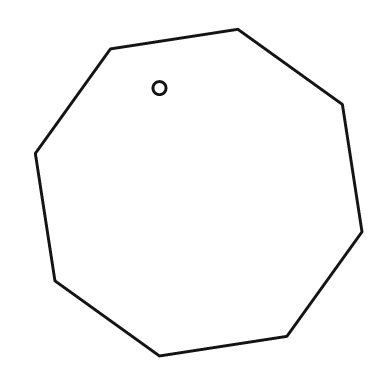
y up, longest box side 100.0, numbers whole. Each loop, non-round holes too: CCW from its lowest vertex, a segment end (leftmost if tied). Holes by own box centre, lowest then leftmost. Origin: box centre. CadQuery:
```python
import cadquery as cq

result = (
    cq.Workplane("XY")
    .moveTo(-12.0, -50.0)
    .lineTo(27.0, -44.0)
    .lineTo(50.0, -12.0)
    .lineTo(44.0, 27.0)
    .lineTo(12.0, 50.0)
    .lineTo(-27.0, 44.0)
    .lineTo(-50.0, 12.0)
    .lineTo(-44.0, -27.0)
    .close()
    .moveTo(-12.0, 32.0)
    .circle(2.0)
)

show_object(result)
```